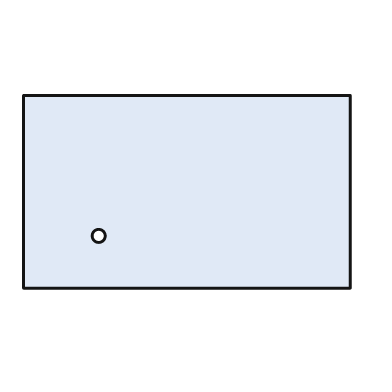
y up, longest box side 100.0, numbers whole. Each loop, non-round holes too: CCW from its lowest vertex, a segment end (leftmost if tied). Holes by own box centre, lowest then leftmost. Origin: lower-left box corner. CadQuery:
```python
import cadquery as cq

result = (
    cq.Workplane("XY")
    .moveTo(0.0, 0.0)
    .lineTo(100.0, 0.0)
    .lineTo(100.0, 59.0)
    .lineTo(0.0, 59.0)
    .close()
    .moveTo(23.0, 16.0)
    .circle(2.0)
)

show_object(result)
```